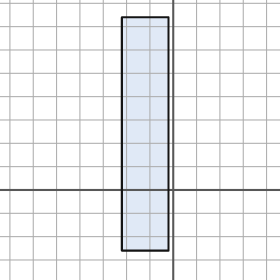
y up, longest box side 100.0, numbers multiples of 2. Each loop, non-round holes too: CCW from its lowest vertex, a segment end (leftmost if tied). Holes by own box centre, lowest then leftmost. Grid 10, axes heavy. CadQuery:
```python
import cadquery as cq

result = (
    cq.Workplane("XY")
    .moveTo(-22.0, -26.0)
    .lineTo(-2.0, -26.0)
    .lineTo(-2.0, 74.0)
    .lineTo(-22.0, 74.0)
    .close()
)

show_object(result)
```